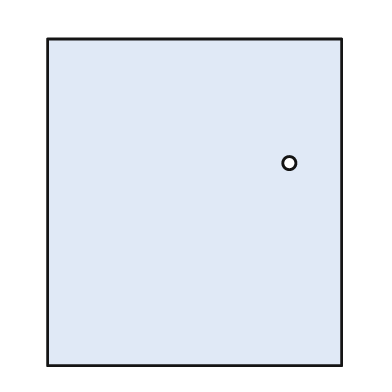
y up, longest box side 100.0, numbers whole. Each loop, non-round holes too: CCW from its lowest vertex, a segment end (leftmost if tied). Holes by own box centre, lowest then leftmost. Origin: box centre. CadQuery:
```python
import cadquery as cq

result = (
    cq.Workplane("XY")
    .moveTo(-45.0, -50.0)
    .lineTo(45.0, -50.0)
    .lineTo(45.0, 50.0)
    .lineTo(-45.0, 50.0)
    .close()
    .moveTo(29.0, 12.0)
    .circle(2.0)
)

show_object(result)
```